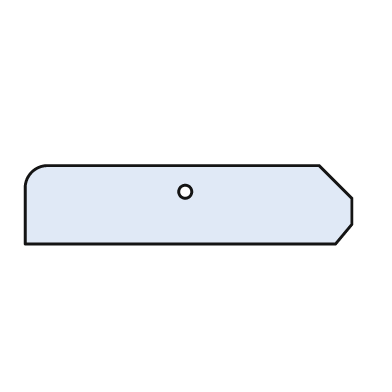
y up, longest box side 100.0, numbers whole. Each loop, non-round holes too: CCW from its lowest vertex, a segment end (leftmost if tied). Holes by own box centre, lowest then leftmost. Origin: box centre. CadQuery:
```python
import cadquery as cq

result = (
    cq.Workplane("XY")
    .moveTo(-50.0, -12.0)
    .lineTo(45.0, -12.0)
    .lineTo(50.0, -6.0)
    .lineTo(50.0, 2.0)
    .lineTo(40.0, 12.0)
    .lineTo(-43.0, 12.0)
    .threePointArc((-48.0, 10.0), (-50.0, 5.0))
    .close()
    .moveTo(-1.0, 4.0)
    .circle(2.0)
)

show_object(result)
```